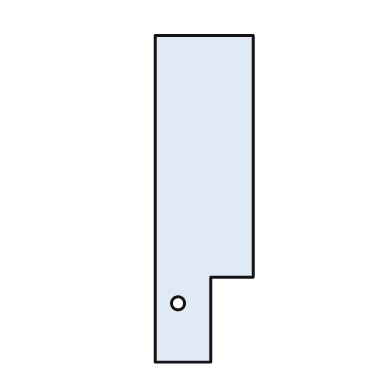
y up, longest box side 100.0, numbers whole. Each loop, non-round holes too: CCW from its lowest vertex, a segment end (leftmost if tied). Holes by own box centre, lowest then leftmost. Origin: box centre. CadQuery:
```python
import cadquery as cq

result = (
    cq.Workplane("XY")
    .moveTo(-15.0, -50.0)
    .lineTo(2.0, -50.0)
    .lineTo(2.0, -24.0)
    .lineTo(15.0, -24.0)
    .lineTo(15.0, 50.0)
    .lineTo(-15.0, 50.0)
    .close()
    .moveTo(-8.0, -32.0)
    .circle(2.0)
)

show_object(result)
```